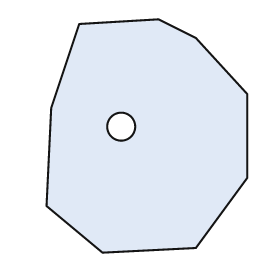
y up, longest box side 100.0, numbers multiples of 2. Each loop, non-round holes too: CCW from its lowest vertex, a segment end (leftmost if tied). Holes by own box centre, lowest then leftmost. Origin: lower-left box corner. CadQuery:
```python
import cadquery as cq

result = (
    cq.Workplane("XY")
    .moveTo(24.0, 0.0)
    .lineTo(64.0, 2.0)
    .lineTo(86.0, 32.0)
    .lineTo(86.0, 68.0)
    .lineTo(64.0, 92.0)
    .lineTo(48.0, 100.0)
    .lineTo(14.0, 98.0)
    .lineTo(2.0, 62.0)
    .lineTo(0.0, 20.0)
    .close()
    .moveTo(32.0, 54.0)
    .circle(6.0)
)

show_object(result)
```